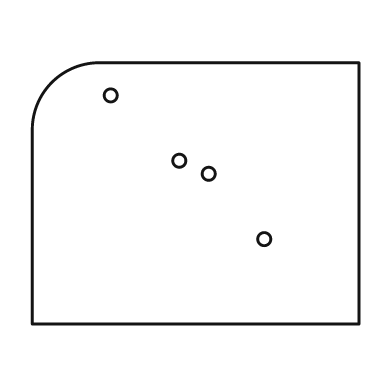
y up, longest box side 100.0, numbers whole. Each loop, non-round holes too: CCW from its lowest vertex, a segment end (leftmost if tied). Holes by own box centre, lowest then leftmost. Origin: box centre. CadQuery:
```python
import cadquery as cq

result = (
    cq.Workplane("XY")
    .moveTo(-50.0, -40.0)
    .lineTo(50.0, -40.0)
    .lineTo(50.0, 40.0)
    .lineTo(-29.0, 40.0)
    .threePointArc((-44.0, 34.0), (-50.0, 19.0))
    .close()
    .moveTo(21.0, -14.0)
    .circle(2.0)
    .moveTo(4.0, 6.0)
    .circle(2.0)
    .moveTo(-5.0, 10.0)
    .circle(2.0)
    .moveTo(-26.0, 30.0)
    .circle(2.0)
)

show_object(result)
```